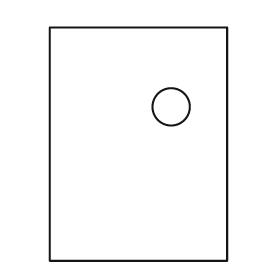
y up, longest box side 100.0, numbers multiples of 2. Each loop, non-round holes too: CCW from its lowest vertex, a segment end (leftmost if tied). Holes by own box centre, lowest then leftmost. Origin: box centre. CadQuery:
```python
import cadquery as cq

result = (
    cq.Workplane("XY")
    .moveTo(-38.0, -50.0)
    .lineTo(38.0, -50.0)
    .lineTo(38.0, 50.0)
    .lineTo(-38.0, 50.0)
    .close()
    .moveTo(14.0, 16.0)
    .circle(8.0)
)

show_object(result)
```